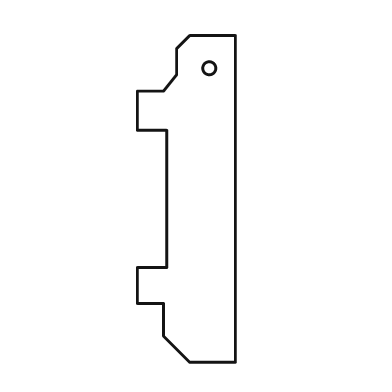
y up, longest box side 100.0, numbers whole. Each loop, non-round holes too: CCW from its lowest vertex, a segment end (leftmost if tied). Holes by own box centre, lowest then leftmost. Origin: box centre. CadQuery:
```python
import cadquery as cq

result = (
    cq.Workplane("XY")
    .moveTo(1.0, -50.0)
    .lineTo(15.0, -50.0)
    .lineTo(15.0, 50.0)
    .lineTo(1.0, 50.0)
    .lineTo(-3.0, 46.0)
    .lineTo(-3.0, 38.0)
    .lineTo(-7.0, 33.0)
    .lineTo(-15.0, 33.0)
    .lineTo(-15.0, 21.0)
    .lineTo(-6.0, 21.0)
    .lineTo(-6.0, -21.0)
    .lineTo(-15.0, -21.0)
    .lineTo(-15.0, -32.0)
    .lineTo(-7.0, -32.0)
    .lineTo(-7.0, -42.0)
    .close()
    .moveTo(7.0, 40.0)
    .circle(2.0)
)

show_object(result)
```